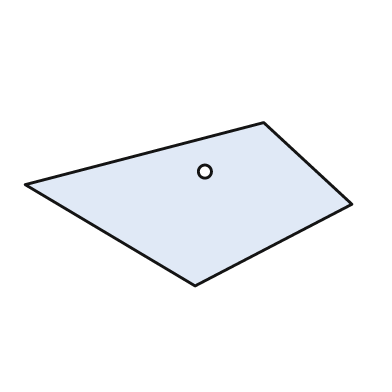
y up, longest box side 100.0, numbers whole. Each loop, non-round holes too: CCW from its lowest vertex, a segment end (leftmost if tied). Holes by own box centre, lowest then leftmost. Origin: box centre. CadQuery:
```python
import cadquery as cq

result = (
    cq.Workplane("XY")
    .moveTo(2.0, -25.0)
    .lineTo(50.0, 0.0)
    .lineTo(23.0, 25.0)
    .lineTo(-50.0, 6.0)
    .close()
    .moveTo(5.0, 10.0)
    .circle(2.0)
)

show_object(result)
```